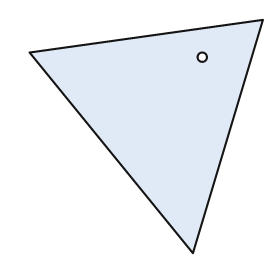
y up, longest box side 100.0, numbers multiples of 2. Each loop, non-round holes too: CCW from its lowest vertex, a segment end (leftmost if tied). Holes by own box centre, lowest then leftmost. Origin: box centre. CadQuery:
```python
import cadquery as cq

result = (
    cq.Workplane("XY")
    .moveTo(20.0, -50.0)
    .lineTo(50.0, 50.0)
    .lineTo(-50.0, 36.0)
    .close()
    .moveTo(24.0, 34.0)
    .circle(2.0)
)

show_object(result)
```